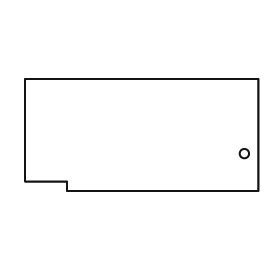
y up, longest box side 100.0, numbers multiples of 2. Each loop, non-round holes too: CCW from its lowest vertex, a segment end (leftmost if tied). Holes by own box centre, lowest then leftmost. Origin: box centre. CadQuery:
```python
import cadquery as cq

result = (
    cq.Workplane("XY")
    .moveTo(-32.0, -24.0)
    .lineTo(50.0, -24.0)
    .lineTo(50.0, 24.0)
    .lineTo(-50.0, 24.0)
    .lineTo(-50.0, -20.0)
    .lineTo(-32.0, -20.0)
    .close()
    .moveTo(44.0, -8.0)
    .circle(2.0)
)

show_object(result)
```